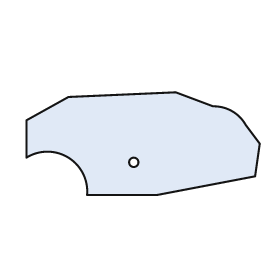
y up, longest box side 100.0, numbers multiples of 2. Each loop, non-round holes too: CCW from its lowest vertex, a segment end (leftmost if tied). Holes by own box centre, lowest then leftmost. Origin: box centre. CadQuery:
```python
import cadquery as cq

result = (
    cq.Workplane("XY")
    .moveTo(-24.0, -22.0)
    .lineTo(6.0, -22.0)
    .lineTo(48.0, -14.0)
    .lineTo(50.0, 0.0)
    .lineTo(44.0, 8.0)
    .threePointArc((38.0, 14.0), (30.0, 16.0))
    .lineTo(14.0, 22.0)
    .lineTo(-32.0, 20.0)
    .lineTo(-50.0, 10.0)
    .lineTo(-50.0, -6.0)
    .threePointArc((-32.0, -6.0), (-24.0, -22.0))
    .close()
    .moveTo(-4.0, -8.0)
    .circle(2.0)
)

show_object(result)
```